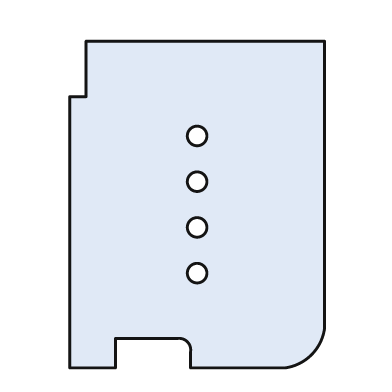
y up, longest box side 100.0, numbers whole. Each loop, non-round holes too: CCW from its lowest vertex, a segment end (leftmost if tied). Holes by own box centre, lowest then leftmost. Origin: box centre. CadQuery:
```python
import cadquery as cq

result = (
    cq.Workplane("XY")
    .moveTo(-39.0, -50.0)
    .lineTo(-25.0, -50.0)
    .lineTo(-25.0, -41.0)
    .lineTo(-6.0, -41.0)
    .threePointArc((-3.0, -42.0), (-2.0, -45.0))
    .lineTo(-2.0, -50.0)
    .lineTo(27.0, -50.0)
    .threePointArc((35.0, -46.0), (39.0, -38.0))
    .lineTo(39.0, 50.0)
    .lineTo(-34.0, 50.0)
    .lineTo(-34.0, 33.0)
    .lineTo(-39.0, 33.0)
    .close()
    .moveTo(0.0, -21.0)
    .circle(3.0)
    .moveTo(0.0, -7.0)
    .circle(3.0)
    .moveTo(0.0, 7.0)
    .circle(3.0)
    .moveTo(0.0, 21.0)
    .circle(3.0)
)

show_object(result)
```